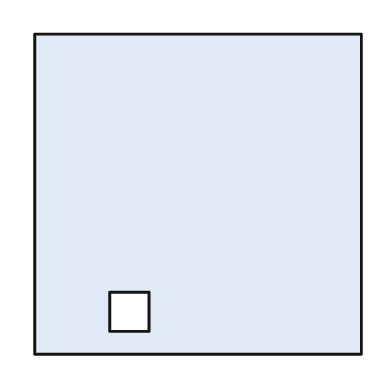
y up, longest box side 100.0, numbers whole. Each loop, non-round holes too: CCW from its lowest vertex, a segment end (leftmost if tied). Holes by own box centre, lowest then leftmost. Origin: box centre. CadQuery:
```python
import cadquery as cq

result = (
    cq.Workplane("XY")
    .moveTo(-50.0, -49.0)
    .lineTo(50.0, -49.0)
    .lineTo(50.0, 49.0)
    .lineTo(-50.0, 49.0)
    .close()
    .moveTo(-27.0, -42.0)
    .lineTo(-15.0, -42.0)
    .lineTo(-15.0, -30.0)
    .lineTo(-27.0, -30.0)
    .close()
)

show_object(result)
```